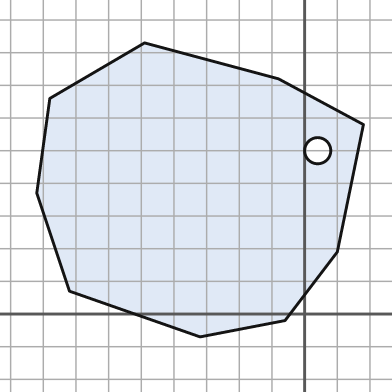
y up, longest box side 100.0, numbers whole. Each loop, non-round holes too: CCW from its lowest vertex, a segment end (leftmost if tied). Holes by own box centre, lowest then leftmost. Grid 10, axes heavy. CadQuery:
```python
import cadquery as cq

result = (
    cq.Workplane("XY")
    .moveTo(-32.0, -7.0)
    .lineTo(-6.0, -2.0)
    .lineTo(10.0, 19.0)
    .lineTo(18.0, 58.0)
    .lineTo(-8.0, 72.0)
    .lineTo(-49.0, 83.0)
    .lineTo(-78.0, 66.0)
    .lineTo(-82.0, 37.0)
    .lineTo(-72.0, 7.0)
    .close()
    .moveTo(4.0, 50.0)
    .circle(4.0)
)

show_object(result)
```